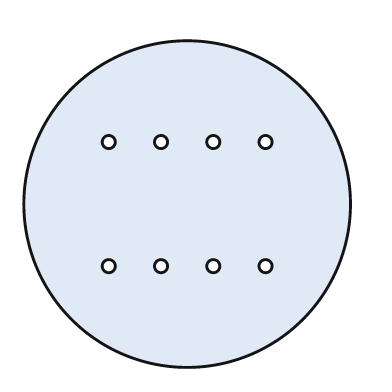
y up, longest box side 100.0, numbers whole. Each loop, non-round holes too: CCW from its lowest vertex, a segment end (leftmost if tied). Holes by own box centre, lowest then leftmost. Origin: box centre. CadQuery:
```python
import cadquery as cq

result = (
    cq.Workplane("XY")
    .moveTo(0.0, 0.0)
    .circle(50.0)
    .moveTo(-24.0, -19.0)
    .circle(2.0)
    .moveTo(-8.0, -19.0)
    .circle(2.0)
    .moveTo(8.0, -19.0)
    .circle(2.0)
    .moveTo(24.0, -19.0)
    .circle(2.0)
    .moveTo(-24.0, 19.0)
    .circle(2.0)
    .moveTo(-8.0, 19.0)
    .circle(2.0)
    .moveTo(8.0, 19.0)
    .circle(2.0)
    .moveTo(24.0, 19.0)
    .circle(2.0)
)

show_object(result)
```